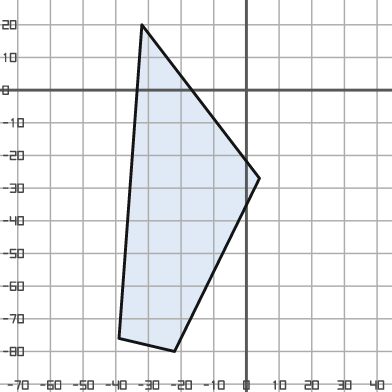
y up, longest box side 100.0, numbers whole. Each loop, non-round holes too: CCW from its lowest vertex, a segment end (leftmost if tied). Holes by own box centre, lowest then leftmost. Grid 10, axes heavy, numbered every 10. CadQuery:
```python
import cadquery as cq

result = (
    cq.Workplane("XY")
    .moveTo(-22.0, -80.0)
    .lineTo(4.0, -27.0)
    .lineTo(-32.0, 20.0)
    .lineTo(-39.0, -76.0)
    .close()
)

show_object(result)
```